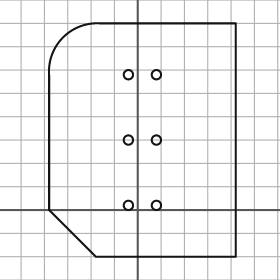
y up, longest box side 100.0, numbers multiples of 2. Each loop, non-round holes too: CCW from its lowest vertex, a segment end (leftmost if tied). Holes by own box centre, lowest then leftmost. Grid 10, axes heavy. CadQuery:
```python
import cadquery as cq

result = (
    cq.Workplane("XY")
    .moveTo(-18.0, -20.0)
    .lineTo(42.0, -20.0)
    .lineTo(42.0, 80.0)
    .lineTo(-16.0, 80.0)
    .threePointArc((-32.0, 74.0), (-38.0, 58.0))
    .lineTo(-38.0, 0.0)
    .close()
    .moveTo(-4.0, 2.0)
    .circle(2.0)
    .moveTo(8.0, 2.0)
    .circle(2.0)
    .moveTo(-4.0, 30.0)
    .circle(2.0)
    .moveTo(8.0, 30.0)
    .circle(2.0)
    .moveTo(-4.0, 58.0)
    .circle(2.0)
    .moveTo(8.0, 58.0)
    .circle(2.0)
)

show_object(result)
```